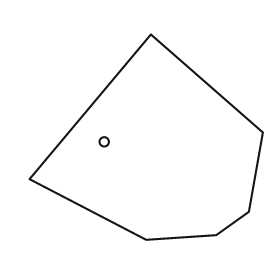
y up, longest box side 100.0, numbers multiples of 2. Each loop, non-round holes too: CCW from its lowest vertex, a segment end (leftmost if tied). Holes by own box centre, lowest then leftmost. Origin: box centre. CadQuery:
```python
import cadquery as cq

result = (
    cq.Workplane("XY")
    .moveTo(0.0, -44.0)
    .lineTo(30.0, -42.0)
    .lineTo(44.0, -32.0)
    .lineTo(50.0, 2.0)
    .lineTo(2.0, 44.0)
    .lineTo(-50.0, -18.0)
    .close()
    .moveTo(-18.0, -2.0)
    .circle(2.0)
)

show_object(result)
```